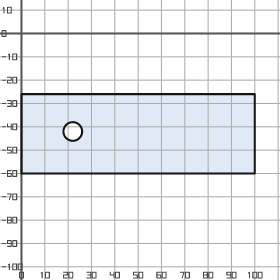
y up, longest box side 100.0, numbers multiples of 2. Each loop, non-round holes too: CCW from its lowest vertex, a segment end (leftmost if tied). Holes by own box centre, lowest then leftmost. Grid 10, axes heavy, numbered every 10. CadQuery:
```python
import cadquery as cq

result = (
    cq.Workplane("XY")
    .moveTo(0.0, -60.0)
    .lineTo(100.0, -60.0)
    .lineTo(100.0, -26.0)
    .lineTo(0.0, -26.0)
    .close()
    .moveTo(22.0, -42.0)
    .circle(4.0)
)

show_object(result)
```